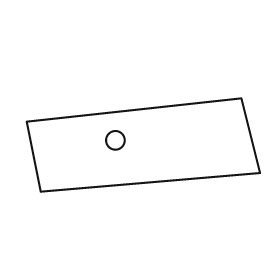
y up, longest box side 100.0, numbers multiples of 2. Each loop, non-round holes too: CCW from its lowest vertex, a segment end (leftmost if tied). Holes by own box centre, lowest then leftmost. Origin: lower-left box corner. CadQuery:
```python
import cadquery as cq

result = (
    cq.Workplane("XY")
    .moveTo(6.0, 0.0)
    .lineTo(100.0, 8.0)
    .lineTo(92.0, 40.0)
    .lineTo(0.0, 30.0)
    .close()
    .moveTo(38.0, 22.0)
    .circle(4.0)
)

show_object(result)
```